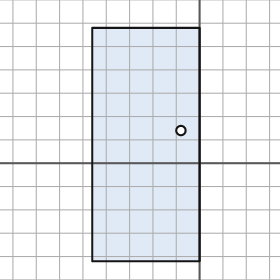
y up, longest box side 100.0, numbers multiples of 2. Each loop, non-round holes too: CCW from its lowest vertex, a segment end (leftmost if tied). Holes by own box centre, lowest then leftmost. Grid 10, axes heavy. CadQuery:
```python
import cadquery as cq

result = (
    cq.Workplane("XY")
    .moveTo(-46.0, -42.0)
    .lineTo(0.0, -42.0)
    .lineTo(0.0, 58.0)
    .lineTo(-46.0, 58.0)
    .close()
    .moveTo(-8.0, 14.0)
    .circle(2.0)
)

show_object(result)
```